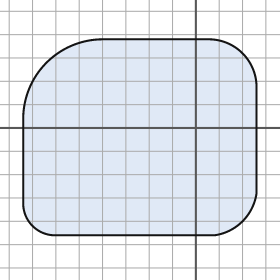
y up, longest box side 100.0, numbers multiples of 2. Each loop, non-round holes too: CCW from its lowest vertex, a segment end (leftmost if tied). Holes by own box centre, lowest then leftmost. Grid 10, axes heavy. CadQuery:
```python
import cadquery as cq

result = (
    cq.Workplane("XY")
    .moveTo(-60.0, -46.0)
    .lineTo(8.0, -46.0)
    .threePointArc((20.0, -40.0), (26.0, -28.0))
    .lineTo(26.0, 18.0)
    .threePointArc((20.0, 32.0), (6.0, 38.0))
    .lineTo(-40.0, 38.0)
    .threePointArc((-64.0, 28.0), (-74.0, 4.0))
    .lineTo(-74.0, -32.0)
    .threePointArc((-70.0, -42.0), (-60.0, -46.0))
    .close()
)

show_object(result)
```